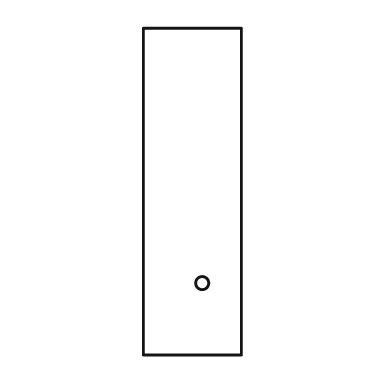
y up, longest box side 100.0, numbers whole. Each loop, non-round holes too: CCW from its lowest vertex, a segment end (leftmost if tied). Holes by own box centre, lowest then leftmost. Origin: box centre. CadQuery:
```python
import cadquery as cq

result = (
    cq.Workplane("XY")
    .moveTo(-15.0, -50.0)
    .lineTo(15.0, -50.0)
    .lineTo(15.0, 50.0)
    .lineTo(-15.0, 50.0)
    .close()
    .moveTo(3.0, -28.0)
    .circle(2.0)
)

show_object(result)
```